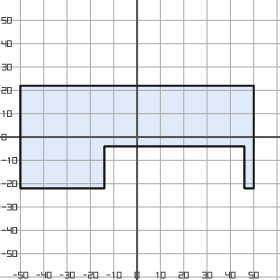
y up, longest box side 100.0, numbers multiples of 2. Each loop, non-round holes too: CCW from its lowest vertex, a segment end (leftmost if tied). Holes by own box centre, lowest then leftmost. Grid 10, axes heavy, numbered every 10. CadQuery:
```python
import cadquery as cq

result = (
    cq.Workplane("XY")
    .moveTo(-50.0, -22.0)
    .lineTo(-14.0, -22.0)
    .lineTo(-14.0, -4.0)
    .lineTo(46.0, -4.0)
    .lineTo(46.0, -22.0)
    .lineTo(50.0, -22.0)
    .lineTo(50.0, 22.0)
    .lineTo(-50.0, 22.0)
    .close()
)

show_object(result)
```